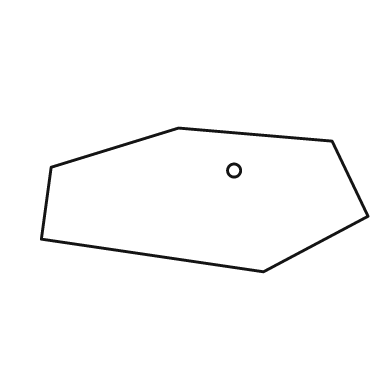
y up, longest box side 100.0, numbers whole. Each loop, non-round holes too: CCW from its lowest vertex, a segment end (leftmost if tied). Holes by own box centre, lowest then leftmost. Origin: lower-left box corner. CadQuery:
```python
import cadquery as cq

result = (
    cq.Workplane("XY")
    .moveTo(68.0, 0.0)
    .lineTo(100.0, 17.0)
    .lineTo(89.0, 40.0)
    .lineTo(42.0, 44.0)
    .lineTo(3.0, 32.0)
    .lineTo(0.0, 10.0)
    .close()
    .moveTo(59.0, 31.0)
    .circle(2.0)
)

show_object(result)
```